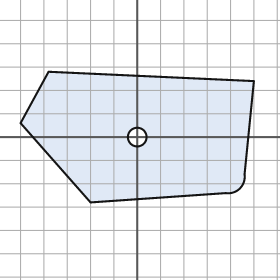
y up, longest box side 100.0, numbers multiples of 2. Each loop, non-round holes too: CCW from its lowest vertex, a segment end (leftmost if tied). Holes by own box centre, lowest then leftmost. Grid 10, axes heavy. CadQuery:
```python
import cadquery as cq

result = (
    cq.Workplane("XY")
    .moveTo(-20.0, -28.0)
    .lineTo(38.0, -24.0)
    .threePointArc((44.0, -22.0), (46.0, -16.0))
    .lineTo(50.0, 24.0)
    .lineTo(-38.0, 28.0)
    .lineTo(-50.0, 6.0)
    .close()
    .moveTo(0.0, 0.0)
    .circle(4.0)
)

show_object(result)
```